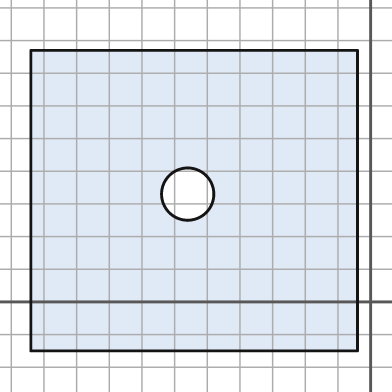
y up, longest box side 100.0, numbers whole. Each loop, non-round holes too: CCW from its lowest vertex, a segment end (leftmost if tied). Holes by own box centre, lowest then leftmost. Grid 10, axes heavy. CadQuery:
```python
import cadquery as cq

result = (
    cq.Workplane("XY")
    .moveTo(-104.0, -15.0)
    .lineTo(-4.0, -15.0)
    .lineTo(-4.0, 77.0)
    .lineTo(-104.0, 77.0)
    .close()
    .moveTo(-56.0, 33.0)
    .circle(8.0)
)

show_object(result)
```